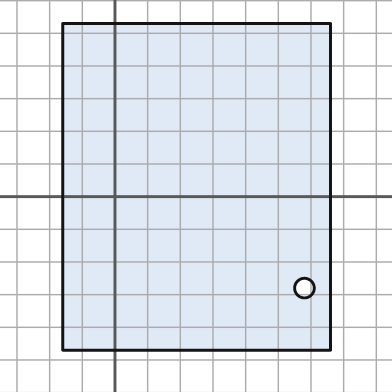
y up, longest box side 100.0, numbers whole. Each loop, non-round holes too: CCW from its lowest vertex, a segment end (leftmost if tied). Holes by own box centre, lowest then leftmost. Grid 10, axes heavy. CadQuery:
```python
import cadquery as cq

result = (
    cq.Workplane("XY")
    .moveTo(-16.0, -47.0)
    .lineTo(66.0, -47.0)
    .lineTo(66.0, 53.0)
    .lineTo(-16.0, 53.0)
    .close()
    .moveTo(58.0, -28.0)
    .circle(3.0)
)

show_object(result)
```